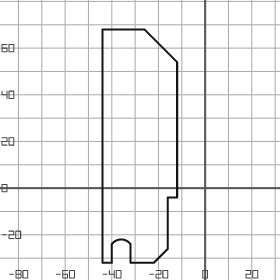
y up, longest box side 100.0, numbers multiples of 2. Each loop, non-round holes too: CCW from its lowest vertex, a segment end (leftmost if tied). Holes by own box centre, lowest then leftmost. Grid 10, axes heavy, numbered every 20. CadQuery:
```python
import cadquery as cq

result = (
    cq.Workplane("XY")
    .moveTo(-44.0, -32.0)
    .lineTo(-40.0, -32.0)
    .lineTo(-40.0, -24.0)
    .threePointArc((-36.0, -22.0), (-32.0, -24.0))
    .lineTo(-32.0, -32.0)
    .lineTo(-22.0, -32.0)
    .lineTo(-16.0, -26.0)
    .lineTo(-16.0, -4.0)
    .lineTo(-12.0, -4.0)
    .lineTo(-12.0, 54.0)
    .lineTo(-26.0, 68.0)
    .lineTo(-44.0, 68.0)
    .close()
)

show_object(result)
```